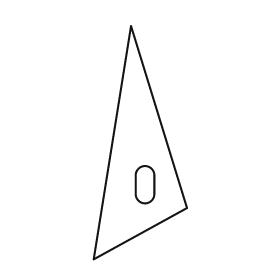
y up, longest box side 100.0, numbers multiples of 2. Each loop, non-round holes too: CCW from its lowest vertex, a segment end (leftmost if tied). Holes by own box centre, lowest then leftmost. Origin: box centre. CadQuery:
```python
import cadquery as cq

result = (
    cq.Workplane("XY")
    .moveTo(-20.0, -50.0)
    .lineTo(20.0, -28.0)
    .lineTo(-4.0, 50.0)
    .close()
    .moveTo(-2.0, -22.0)
    .threePointArc((2.0, -26.0), (6.0, -22.0))
    .lineTo(6.0, -14.0)
    .threePointArc((2.0, -10.0), (-2.0, -14.0))
    .close()
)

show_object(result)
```